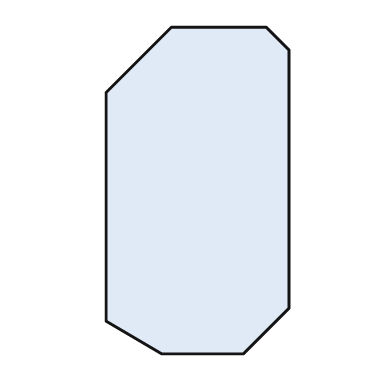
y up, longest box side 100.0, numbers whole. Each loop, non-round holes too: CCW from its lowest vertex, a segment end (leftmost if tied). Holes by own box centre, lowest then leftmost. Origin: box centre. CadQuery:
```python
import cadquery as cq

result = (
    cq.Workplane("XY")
    .moveTo(-11.0, -50.0)
    .lineTo(14.0, -50.0)
    .lineTo(28.0, -36.0)
    .lineTo(28.0, 43.0)
    .lineTo(21.0, 50.0)
    .lineTo(-8.0, 50.0)
    .lineTo(-28.0, 30.0)
    .lineTo(-28.0, -40.0)
    .close()
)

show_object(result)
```